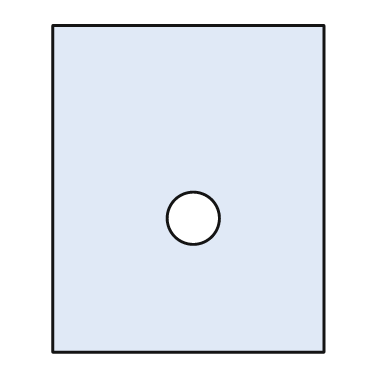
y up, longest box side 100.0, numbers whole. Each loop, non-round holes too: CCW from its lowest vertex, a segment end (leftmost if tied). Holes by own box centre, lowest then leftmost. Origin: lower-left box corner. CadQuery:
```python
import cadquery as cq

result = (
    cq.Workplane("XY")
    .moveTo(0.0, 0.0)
    .lineTo(83.0, 0.0)
    .lineTo(83.0, 100.0)
    .lineTo(0.0, 100.0)
    .close()
    .moveTo(43.0, 41.0)
    .circle(8.0)
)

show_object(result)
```